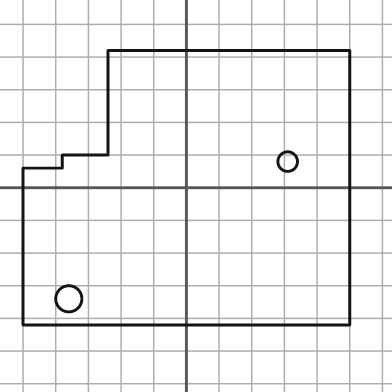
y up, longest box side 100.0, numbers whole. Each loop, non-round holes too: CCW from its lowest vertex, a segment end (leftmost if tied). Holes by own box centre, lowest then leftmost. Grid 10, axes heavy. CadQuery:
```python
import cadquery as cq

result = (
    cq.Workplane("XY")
    .moveTo(-50.0, -42.0)
    .lineTo(50.0, -42.0)
    .lineTo(50.0, 42.0)
    .lineTo(-24.0, 42.0)
    .lineTo(-24.0, 10.0)
    .lineTo(-38.0, 10.0)
    .lineTo(-38.0, 6.0)
    .lineTo(-50.0, 6.0)
    .close()
    .moveTo(-36.0, -34.0)
    .circle(4.0)
    .moveTo(31.0, 8.0)
    .circle(3.0)
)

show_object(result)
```